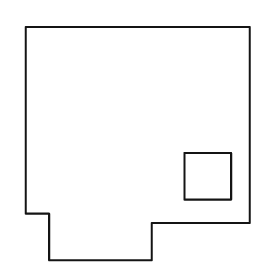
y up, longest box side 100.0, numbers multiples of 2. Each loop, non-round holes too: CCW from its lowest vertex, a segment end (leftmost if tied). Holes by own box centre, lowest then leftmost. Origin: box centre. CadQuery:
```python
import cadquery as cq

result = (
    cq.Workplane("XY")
    .moveTo(-38.0, -50.0)
    .lineTo(6.0, -50.0)
    .lineTo(6.0, -34.0)
    .lineTo(48.0, -34.0)
    .lineTo(48.0, 50.0)
    .lineTo(-48.0, 50.0)
    .lineTo(-48.0, -30.0)
    .lineTo(-38.0, -30.0)
    .close()
    .moveTo(20.0, -24.0)
    .lineTo(40.0, -24.0)
    .lineTo(40.0, -4.0)
    .lineTo(20.0, -4.0)
    .close()
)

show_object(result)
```